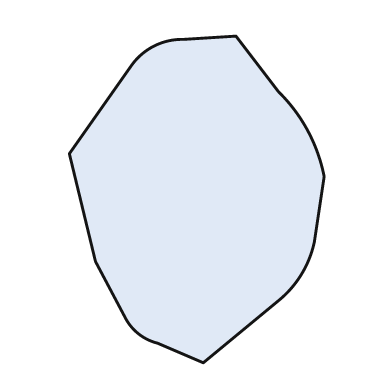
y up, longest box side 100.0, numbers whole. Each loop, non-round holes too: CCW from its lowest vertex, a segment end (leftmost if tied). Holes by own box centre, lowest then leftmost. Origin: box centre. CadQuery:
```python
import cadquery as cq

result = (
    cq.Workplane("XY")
    .moveTo(2.0, -50.0)
    .lineTo(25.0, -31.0)
    .threePointArc((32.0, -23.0), (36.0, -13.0))
    .lineTo(39.0, 7.0)
    .threePointArc((34.0, 21.0), (25.0, 33.0))
    .lineTo(12.0, 50.0)
    .lineTo(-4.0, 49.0)
    .threePointArc((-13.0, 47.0), (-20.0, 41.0))
    .lineTo(-39.0, 14.0)
    .lineTo(-31.0, -19.0)
    .lineTo(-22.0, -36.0)
    .threePointArc((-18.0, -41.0), (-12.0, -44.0))
    .close()
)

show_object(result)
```